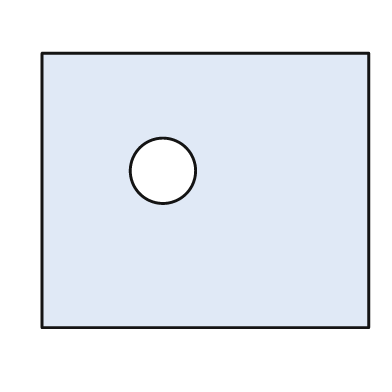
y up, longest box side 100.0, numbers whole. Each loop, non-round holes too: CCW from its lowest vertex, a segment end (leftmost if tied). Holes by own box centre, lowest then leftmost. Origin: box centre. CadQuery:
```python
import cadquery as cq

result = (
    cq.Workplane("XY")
    .moveTo(-50.0, -42.0)
    .lineTo(50.0, -42.0)
    .lineTo(50.0, 42.0)
    .lineTo(-50.0, 42.0)
    .close()
    .moveTo(-13.0, 6.0)
    .circle(10.0)
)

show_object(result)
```